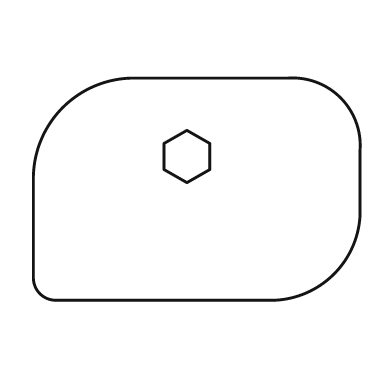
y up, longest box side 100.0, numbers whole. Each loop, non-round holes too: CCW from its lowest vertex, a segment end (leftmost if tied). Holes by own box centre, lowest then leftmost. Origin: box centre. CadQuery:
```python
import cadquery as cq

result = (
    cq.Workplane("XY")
    .moveTo(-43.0, -34.0)
    .lineTo(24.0, -34.0)
    .threePointArc((42.0, -26.0), (50.0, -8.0))
    .lineTo(50.0, 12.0)
    .threePointArc((44.0, 28.0), (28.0, 34.0))
    .lineTo(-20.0, 34.0)
    .threePointArc((-41.0, 25.0), (-50.0, 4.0))
    .lineTo(-50.0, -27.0)
    .threePointArc((-48.0, -32.0), (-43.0, -34.0))
    .close()
    .moveTo(-3.0, 2.0)
    .lineTo(4.0, 6.0)
    .lineTo(4.0, 14.0)
    .lineTo(-3.0, 18.0)
    .lineTo(-10.0, 14.0)
    .lineTo(-10.0, 6.0)
    .close()
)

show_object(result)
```